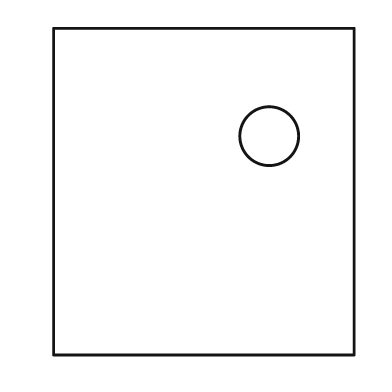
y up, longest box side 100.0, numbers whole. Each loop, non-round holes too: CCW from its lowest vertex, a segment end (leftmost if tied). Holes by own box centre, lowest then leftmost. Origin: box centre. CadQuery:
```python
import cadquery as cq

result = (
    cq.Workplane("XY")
    .moveTo(-46.0, -50.0)
    .lineTo(46.0, -50.0)
    .lineTo(46.0, 50.0)
    .lineTo(-46.0, 50.0)
    .close()
    .moveTo(20.0, 17.0)
    .circle(9.0)
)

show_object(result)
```